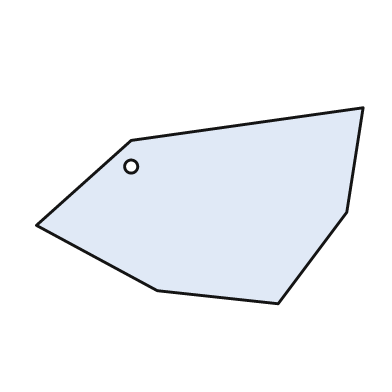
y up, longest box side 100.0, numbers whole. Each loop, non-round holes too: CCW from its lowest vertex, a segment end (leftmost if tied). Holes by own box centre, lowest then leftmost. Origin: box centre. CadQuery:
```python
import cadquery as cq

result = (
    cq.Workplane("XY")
    .moveTo(24.0, -30.0)
    .lineTo(45.0, -2.0)
    .lineTo(50.0, 30.0)
    .lineTo(-21.0, 20.0)
    .lineTo(-50.0, -6.0)
    .lineTo(-13.0, -26.0)
    .close()
    .moveTo(-21.0, 12.0)
    .circle(2.0)
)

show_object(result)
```